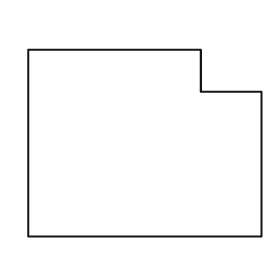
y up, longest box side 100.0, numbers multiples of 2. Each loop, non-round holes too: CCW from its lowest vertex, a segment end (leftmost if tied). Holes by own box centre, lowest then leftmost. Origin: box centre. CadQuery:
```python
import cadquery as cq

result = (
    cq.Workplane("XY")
    .moveTo(-50.0, -40.0)
    .lineTo(50.0, -40.0)
    .lineTo(50.0, 22.0)
    .lineTo(24.0, 22.0)
    .lineTo(24.0, 40.0)
    .lineTo(-50.0, 40.0)
    .close()
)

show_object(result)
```